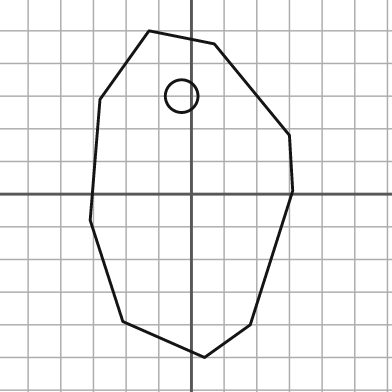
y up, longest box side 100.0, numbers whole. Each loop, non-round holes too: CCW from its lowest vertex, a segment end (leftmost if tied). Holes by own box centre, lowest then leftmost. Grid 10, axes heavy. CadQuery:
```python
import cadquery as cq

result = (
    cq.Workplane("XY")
    .moveTo(4.0, -50.0)
    .lineTo(18.0, -40.0)
    .lineTo(31.0, 1.0)
    .lineTo(30.0, 18.0)
    .lineTo(7.0, 46.0)
    .lineTo(-13.0, 50.0)
    .lineTo(-28.0, 29.0)
    .lineTo(-31.0, -8.0)
    .lineTo(-21.0, -39.0)
    .close()
    .moveTo(-3.0, 30.0)
    .circle(5.0)
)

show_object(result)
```